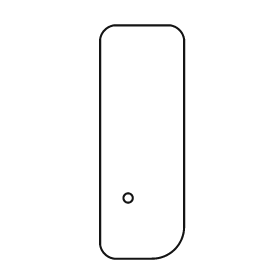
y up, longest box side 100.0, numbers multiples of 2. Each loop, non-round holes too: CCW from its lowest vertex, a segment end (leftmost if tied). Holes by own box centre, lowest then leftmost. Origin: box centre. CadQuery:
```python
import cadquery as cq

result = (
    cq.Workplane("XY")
    .moveTo(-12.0, -50.0)
    .lineTo(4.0, -50.0)
    .threePointArc((14.0, -46.0), (18.0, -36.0))
    .lineTo(18.0, 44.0)
    .threePointArc((16.0, 48.0), (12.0, 50.0))
    .lineTo(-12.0, 50.0)
    .threePointArc((-16.0, 48.0), (-18.0, 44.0))
    .lineTo(-18.0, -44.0)
    .threePointArc((-16.0, -48.0), (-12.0, -50.0))
    .close()
    .moveTo(-6.0, -24.0)
    .circle(2.0)
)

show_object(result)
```